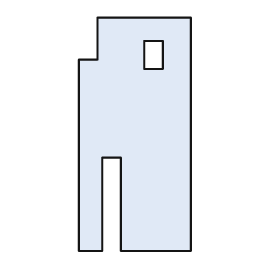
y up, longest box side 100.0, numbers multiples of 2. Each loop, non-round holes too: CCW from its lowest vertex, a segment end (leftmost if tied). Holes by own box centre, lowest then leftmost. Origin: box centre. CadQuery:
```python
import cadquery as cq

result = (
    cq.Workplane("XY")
    .moveTo(-24.0, -50.0)
    .lineTo(-14.0, -50.0)
    .lineTo(-14.0, -10.0)
    .lineTo(-6.0, -10.0)
    .lineTo(-6.0, -50.0)
    .lineTo(24.0, -50.0)
    .lineTo(24.0, 50.0)
    .lineTo(-16.0, 50.0)
    .lineTo(-16.0, 32.0)
    .lineTo(-24.0, 32.0)
    .close()
    .moveTo(4.0, 28.0)
    .lineTo(12.0, 28.0)
    .lineTo(12.0, 40.0)
    .lineTo(4.0, 40.0)
    .close()
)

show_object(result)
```